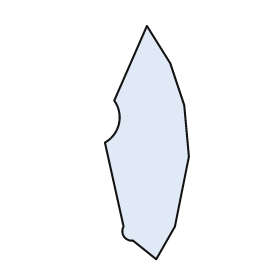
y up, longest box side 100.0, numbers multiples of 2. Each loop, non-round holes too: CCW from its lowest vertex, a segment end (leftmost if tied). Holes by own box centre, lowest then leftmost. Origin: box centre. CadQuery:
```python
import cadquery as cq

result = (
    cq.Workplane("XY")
    .moveTo(4.0, -50.0)
    .lineTo(12.0, -36.0)
    .lineTo(18.0, -6.0)
    .lineTo(16.0, 16.0)
    .lineTo(10.0, 34.0)
    .lineTo(0.0, 50.0)
    .lineTo(-14.0, 18.0)
    .threePointArc((-12.0, 8.0), (-18.0, 0.0))
    .lineTo(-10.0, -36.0)
    .threePointArc((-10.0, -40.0), (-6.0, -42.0))
    .close()
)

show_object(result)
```